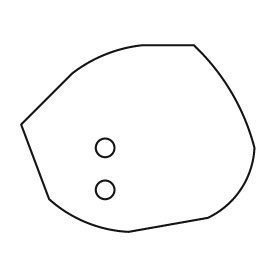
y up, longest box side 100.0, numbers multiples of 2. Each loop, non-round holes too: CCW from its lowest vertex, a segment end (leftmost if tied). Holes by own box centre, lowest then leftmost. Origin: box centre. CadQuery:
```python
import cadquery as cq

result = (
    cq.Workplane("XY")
    .moveTo(-4.0, -40.0)
    .lineTo(30.0, -34.0)
    .threePointArc((44.0, -22.0), (50.0, -4.0))
    .threePointArc((40.0, 20.0), (24.0, 40.0))
    .lineTo(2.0, 40.0)
    .threePointArc((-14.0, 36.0), (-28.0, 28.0))
    .lineTo(-50.0, 6.0)
    .lineTo(-38.0, -26.0)
    .threePointArc((-22.0, -36.0), (-4.0, -40.0))
    .close()
    .moveTo(-14.0, -22.0)
    .circle(4.0)
    .moveTo(-14.0, -4.0)
    .circle(4.0)
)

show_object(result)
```